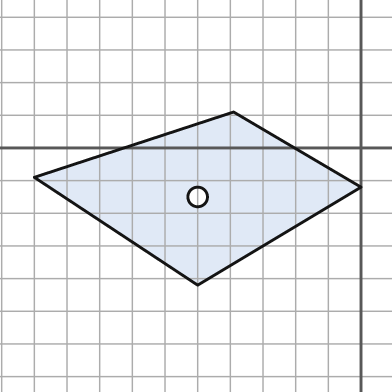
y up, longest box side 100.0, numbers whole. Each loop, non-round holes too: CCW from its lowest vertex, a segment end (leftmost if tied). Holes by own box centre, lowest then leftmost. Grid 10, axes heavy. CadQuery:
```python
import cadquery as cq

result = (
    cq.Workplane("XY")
    .moveTo(-50.0, -42.0)
    .lineTo(0.0, -12.0)
    .lineTo(-39.0, 11.0)
    .lineTo(-100.0, -9.0)
    .close()
    .moveTo(-50.0, -15.0)
    .circle(3.0)
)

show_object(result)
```